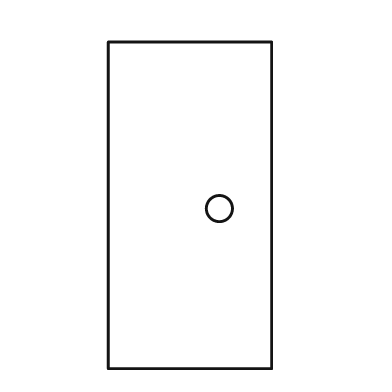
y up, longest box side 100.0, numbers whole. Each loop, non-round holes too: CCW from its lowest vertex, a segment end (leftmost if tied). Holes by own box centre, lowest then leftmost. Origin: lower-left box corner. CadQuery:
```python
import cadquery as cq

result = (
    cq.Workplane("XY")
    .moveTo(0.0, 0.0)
    .lineTo(50.0, 0.0)
    .lineTo(50.0, 100.0)
    .lineTo(0.0, 100.0)
    .close()
    .moveTo(34.0, 49.0)
    .circle(4.0)
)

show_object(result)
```